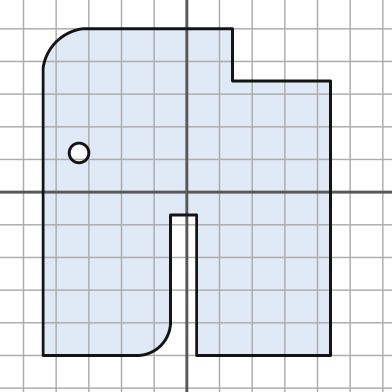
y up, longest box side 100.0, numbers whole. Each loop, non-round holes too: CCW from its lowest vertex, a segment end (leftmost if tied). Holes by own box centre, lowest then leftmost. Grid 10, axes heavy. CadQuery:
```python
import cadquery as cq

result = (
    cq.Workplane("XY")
    .moveTo(-44.0, -50.0)
    .lineTo(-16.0, -50.0)
    .threePointArc((-8.0, -47.0), (-5.0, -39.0))
    .lineTo(-5.0, -7.0)
    .lineTo(3.0, -7.0)
    .lineTo(3.0, -50.0)
    .lineTo(44.0, -50.0)
    .lineTo(44.0, 34.0)
    .lineTo(14.0, 34.0)
    .lineTo(14.0, 50.0)
    .lineTo(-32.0, 50.0)
    .threePointArc((-40.0, 46.0), (-44.0, 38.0))
    .close()
    .moveTo(-33.0, 12.0)
    .circle(3.0)
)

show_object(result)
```